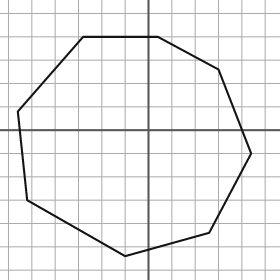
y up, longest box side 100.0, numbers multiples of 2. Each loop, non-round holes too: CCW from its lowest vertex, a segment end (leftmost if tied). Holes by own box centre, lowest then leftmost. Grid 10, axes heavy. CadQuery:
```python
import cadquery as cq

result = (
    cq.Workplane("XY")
    .moveTo(-10.0, -54.0)
    .lineTo(26.0, -44.0)
    .lineTo(44.0, -10.0)
    .lineTo(30.0, 26.0)
    .lineTo(4.0, 40.0)
    .lineTo(-28.0, 40.0)
    .lineTo(-56.0, 8.0)
    .lineTo(-52.0, -30.0)
    .close()
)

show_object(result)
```